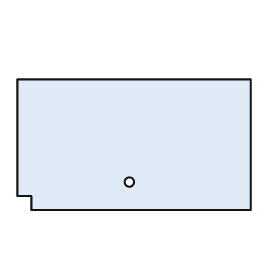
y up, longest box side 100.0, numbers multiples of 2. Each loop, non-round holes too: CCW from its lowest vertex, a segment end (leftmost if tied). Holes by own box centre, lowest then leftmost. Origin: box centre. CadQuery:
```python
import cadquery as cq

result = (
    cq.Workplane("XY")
    .moveTo(-44.0, -28.0)
    .lineTo(50.0, -28.0)
    .lineTo(50.0, 28.0)
    .lineTo(-50.0, 28.0)
    .lineTo(-50.0, -22.0)
    .lineTo(-44.0, -22.0)
    .close()
    .moveTo(-2.0, -16.0)
    .circle(2.0)
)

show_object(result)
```